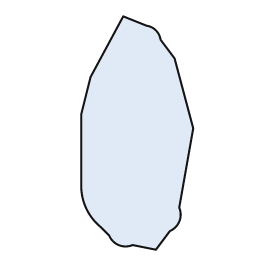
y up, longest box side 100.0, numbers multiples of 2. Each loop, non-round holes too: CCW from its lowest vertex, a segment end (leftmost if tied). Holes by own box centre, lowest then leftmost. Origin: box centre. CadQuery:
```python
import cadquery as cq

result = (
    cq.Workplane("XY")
    .moveTo(8.0, -50.0)
    .lineTo(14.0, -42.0)
    .threePointArc((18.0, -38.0), (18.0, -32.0))
    .lineTo(24.0, 2.0)
    .lineTo(16.0, 32.0)
    .lineTo(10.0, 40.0)
    .threePointArc((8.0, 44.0), (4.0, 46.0))
    .lineTo(-6.0, 50.0)
    .lineTo(-20.0, 24.0)
    .lineTo(-24.0, 8.0)
    .lineTo(-24.0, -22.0)
    .threePointArc((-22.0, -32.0), (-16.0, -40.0))
    .lineTo(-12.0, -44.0)
    .threePointArc((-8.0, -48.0), (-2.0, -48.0))
    .close()
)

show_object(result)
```